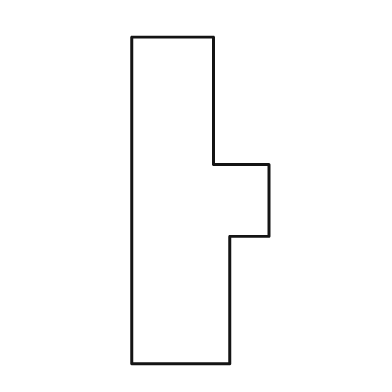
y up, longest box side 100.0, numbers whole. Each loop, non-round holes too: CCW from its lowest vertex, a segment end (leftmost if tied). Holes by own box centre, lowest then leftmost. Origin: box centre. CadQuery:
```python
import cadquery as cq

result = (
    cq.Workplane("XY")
    .moveTo(-21.0, -50.0)
    .lineTo(9.0, -50.0)
    .lineTo(9.0, -11.0)
    .lineTo(21.0, -11.0)
    .lineTo(21.0, 11.0)
    .lineTo(4.0, 11.0)
    .lineTo(4.0, 50.0)
    .lineTo(-21.0, 50.0)
    .close()
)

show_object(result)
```